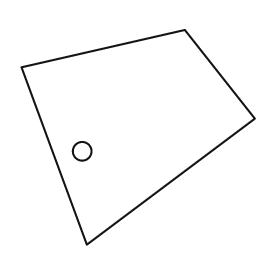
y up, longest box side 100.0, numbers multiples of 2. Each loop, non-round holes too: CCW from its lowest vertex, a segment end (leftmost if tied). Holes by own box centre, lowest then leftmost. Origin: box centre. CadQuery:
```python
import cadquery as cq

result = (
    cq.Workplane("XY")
    .moveTo(-22.0, -46.0)
    .lineTo(50.0, 8.0)
    .lineTo(20.0, 46.0)
    .lineTo(-50.0, 30.0)
    .close()
    .moveTo(-24.0, -6.0)
    .circle(4.0)
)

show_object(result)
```